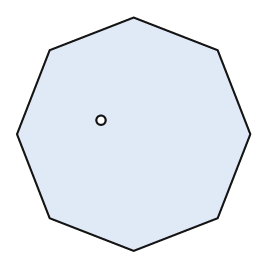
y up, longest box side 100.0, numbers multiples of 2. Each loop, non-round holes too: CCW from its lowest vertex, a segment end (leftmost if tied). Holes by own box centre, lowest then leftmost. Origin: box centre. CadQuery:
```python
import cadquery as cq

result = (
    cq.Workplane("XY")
    .moveTo(0.0, -50.0)
    .lineTo(36.0, -36.0)
    .lineTo(50.0, 0.0)
    .lineTo(36.0, 36.0)
    .lineTo(0.0, 50.0)
    .lineTo(-36.0, 36.0)
    .lineTo(-50.0, 0.0)
    .lineTo(-36.0, -36.0)
    .close()
    .moveTo(-14.0, 6.0)
    .circle(2.0)
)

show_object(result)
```